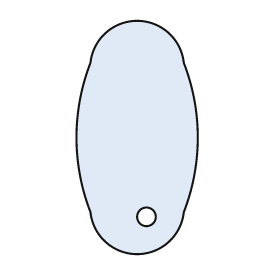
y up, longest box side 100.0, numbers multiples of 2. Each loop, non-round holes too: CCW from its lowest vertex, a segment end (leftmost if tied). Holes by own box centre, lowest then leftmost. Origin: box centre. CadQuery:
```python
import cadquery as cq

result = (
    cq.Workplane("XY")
    .moveTo(-20.0, -32.0)
    .threePointArc((0.0, -50.0), (20.0, -32.0))
    .threePointArc((26.0, 0.0), (20.0, 32.0))
    .threePointArc((0.0, 50.0), (-20.0, 32.0))
    .threePointArc((-26.0, 0.0), (-20.0, -32.0))
    .close()
    .moveTo(4.0, -34.0)
    .circle(4.0)
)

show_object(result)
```